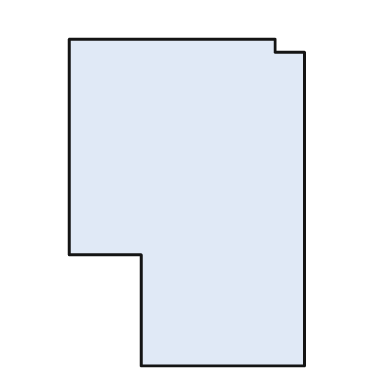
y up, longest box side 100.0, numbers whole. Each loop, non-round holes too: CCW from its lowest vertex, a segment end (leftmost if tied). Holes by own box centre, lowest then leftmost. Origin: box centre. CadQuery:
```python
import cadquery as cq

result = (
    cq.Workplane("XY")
    .moveTo(-14.0, -50.0)
    .lineTo(36.0, -50.0)
    .lineTo(36.0, 46.0)
    .lineTo(27.0, 46.0)
    .lineTo(27.0, 50.0)
    .lineTo(-36.0, 50.0)
    .lineTo(-36.0, -16.0)
    .lineTo(-14.0, -16.0)
    .close()
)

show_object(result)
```